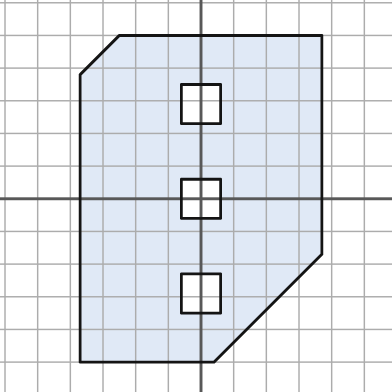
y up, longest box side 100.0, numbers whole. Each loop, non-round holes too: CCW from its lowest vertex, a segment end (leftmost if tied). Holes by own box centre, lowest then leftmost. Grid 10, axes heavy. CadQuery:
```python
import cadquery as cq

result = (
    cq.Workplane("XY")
    .moveTo(-37.0, -50.0)
    .lineTo(4.0, -50.0)
    .lineTo(37.0, -17.0)
    .lineTo(37.0, 50.0)
    .lineTo(-25.0, 50.0)
    .lineTo(-37.0, 38.0)
    .close()
    .moveTo(-6.0, -35.0)
    .lineTo(6.0, -35.0)
    .lineTo(6.0, -23.0)
    .lineTo(-6.0, -23.0)
    .close()
    .moveTo(-6.0, -6.0)
    .lineTo(6.0, -6.0)
    .lineTo(6.0, 6.0)
    .lineTo(-6.0, 6.0)
    .close()
    .moveTo(-6.0, 23.0)
    .lineTo(6.0, 23.0)
    .lineTo(6.0, 35.0)
    .lineTo(-6.0, 35.0)
    .close()
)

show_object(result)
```